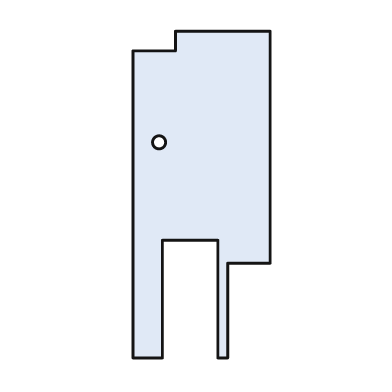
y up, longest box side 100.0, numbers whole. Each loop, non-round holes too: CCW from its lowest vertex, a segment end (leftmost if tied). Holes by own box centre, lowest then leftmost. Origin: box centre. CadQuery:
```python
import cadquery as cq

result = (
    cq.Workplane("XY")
    .moveTo(-21.0, -50.0)
    .lineTo(-12.0, -50.0)
    .lineTo(-12.0, -14.0)
    .lineTo(5.0, -14.0)
    .lineTo(5.0, -50.0)
    .lineTo(8.0, -50.0)
    .lineTo(8.0, -21.0)
    .lineTo(21.0, -21.0)
    .lineTo(21.0, 50.0)
    .lineTo(-8.0, 50.0)
    .lineTo(-8.0, 44.0)
    .lineTo(-21.0, 44.0)
    .close()
    .moveTo(-13.0, 16.0)
    .circle(2.0)
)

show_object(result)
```